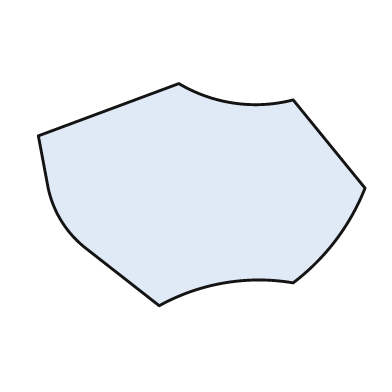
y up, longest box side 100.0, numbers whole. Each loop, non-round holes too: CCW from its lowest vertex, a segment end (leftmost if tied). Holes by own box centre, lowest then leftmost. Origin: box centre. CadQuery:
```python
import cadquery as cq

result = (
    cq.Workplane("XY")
    .moveTo(-13.0, -34.0)
    .threePointArc((7.0, -27.0), (28.0, -27.0))
    .threePointArc((41.0, -14.0), (50.0, 2.0))
    .lineTo(28.0, 29.0)
    .threePointArc((10.0, 28.0), (-7.0, 34.0))
    .lineTo(-50.0, 18.0)
    .lineTo(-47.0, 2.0)
    .threePointArc((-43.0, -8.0), (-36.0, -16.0))
    .close()
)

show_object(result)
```